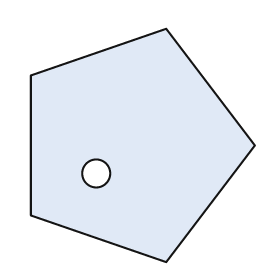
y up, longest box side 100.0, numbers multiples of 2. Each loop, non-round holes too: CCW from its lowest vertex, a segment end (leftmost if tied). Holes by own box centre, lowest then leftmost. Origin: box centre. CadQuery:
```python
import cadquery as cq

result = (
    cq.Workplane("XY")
    .moveTo(10.0, -50.0)
    .lineTo(48.0, 0.0)
    .lineTo(10.0, 50.0)
    .lineTo(-48.0, 30.0)
    .lineTo(-48.0, -30.0)
    .close()
    .moveTo(-20.0, -12.0)
    .circle(6.0)
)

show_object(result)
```